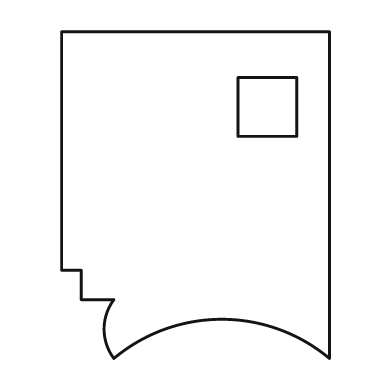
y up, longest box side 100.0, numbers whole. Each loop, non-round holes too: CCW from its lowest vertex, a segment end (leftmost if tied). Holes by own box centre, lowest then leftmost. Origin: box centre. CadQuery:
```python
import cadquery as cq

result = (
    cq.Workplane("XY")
    .moveTo(-25.0, -50.0)
    .threePointArc((8.0, -38.0), (41.0, -50.0))
    .lineTo(41.0, 50.0)
    .lineTo(-41.0, 50.0)
    .lineTo(-41.0, -23.0)
    .lineTo(-35.0, -23.0)
    .lineTo(-35.0, -32.0)
    .lineTo(-25.0, -32.0)
    .threePointArc((-28.0, -41.0), (-25.0, -50.0))
    .close()
    .moveTo(13.0, 18.0)
    .lineTo(31.0, 18.0)
    .lineTo(31.0, 36.0)
    .lineTo(13.0, 36.0)
    .close()
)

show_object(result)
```